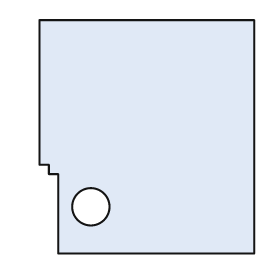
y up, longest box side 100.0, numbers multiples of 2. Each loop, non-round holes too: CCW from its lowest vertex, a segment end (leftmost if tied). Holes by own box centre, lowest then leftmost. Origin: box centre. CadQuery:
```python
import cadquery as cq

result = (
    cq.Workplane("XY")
    .moveTo(-38.0, -50.0)
    .lineTo(46.0, -50.0)
    .lineTo(46.0, 50.0)
    .lineTo(-46.0, 50.0)
    .lineTo(-46.0, -12.0)
    .lineTo(-42.0, -12.0)
    .lineTo(-42.0, -16.0)
    .lineTo(-38.0, -16.0)
    .close()
    .moveTo(-24.0, -30.0)
    .circle(8.0)
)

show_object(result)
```